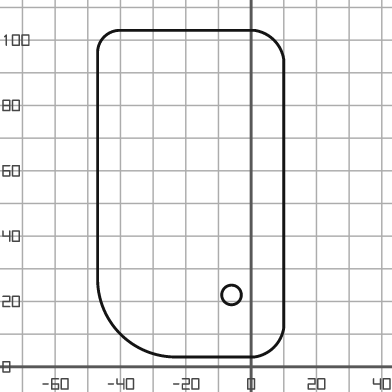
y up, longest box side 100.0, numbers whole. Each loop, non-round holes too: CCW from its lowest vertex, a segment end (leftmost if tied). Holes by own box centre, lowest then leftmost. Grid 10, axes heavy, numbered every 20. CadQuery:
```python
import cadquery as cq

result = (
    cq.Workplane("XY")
    .moveTo(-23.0, 3.0)
    .lineTo(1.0, 3.0)
    .threePointArc((7.0, 6.0), (10.0, 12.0))
    .lineTo(10.0, 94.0)
    .threePointArc((7.0, 100.0), (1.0, 103.0))
    .lineTo(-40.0, 103.0)
    .threePointArc((-45.0, 101.0), (-47.0, 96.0))
    .lineTo(-47.0, 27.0)
    .threePointArc((-40.0, 10.0), (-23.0, 3.0))
    .close()
    .moveTo(-6.0, 22.0)
    .circle(3.0)
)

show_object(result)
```